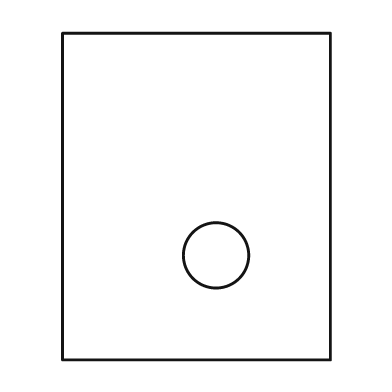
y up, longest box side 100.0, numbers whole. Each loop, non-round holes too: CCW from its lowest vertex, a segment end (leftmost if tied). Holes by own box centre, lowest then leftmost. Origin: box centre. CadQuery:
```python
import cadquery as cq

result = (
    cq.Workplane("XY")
    .moveTo(-41.0, -50.0)
    .lineTo(41.0, -50.0)
    .lineTo(41.0, 50.0)
    .lineTo(-41.0, 50.0)
    .close()
    .moveTo(6.0, -18.0)
    .circle(10.0)
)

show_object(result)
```